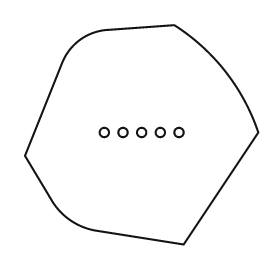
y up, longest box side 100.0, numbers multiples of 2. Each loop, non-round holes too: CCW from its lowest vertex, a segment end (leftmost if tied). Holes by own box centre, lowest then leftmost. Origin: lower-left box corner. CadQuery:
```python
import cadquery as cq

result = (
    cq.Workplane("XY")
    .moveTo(68.0, 0.0)
    .lineTo(100.0, 48.0)
    .threePointArc((86.0, 74.0), (64.0, 94.0))
    .lineTo(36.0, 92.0)
    .threePointArc((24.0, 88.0), (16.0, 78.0))
    .lineTo(0.0, 38.0)
    .lineTo(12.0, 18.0)
    .threePointArc((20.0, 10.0), (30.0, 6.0))
    .close()
    .moveTo(34.0, 48.0)
    .circle(2.0)
    .moveTo(42.0, 48.0)
    .circle(2.0)
    .moveTo(50.0, 48.0)
    .circle(2.0)
    .moveTo(58.0, 48.0)
    .circle(2.0)
    .moveTo(66.0, 48.0)
    .circle(2.0)
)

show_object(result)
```